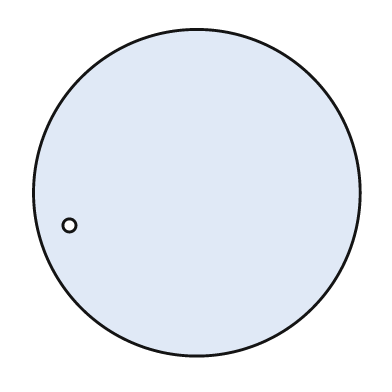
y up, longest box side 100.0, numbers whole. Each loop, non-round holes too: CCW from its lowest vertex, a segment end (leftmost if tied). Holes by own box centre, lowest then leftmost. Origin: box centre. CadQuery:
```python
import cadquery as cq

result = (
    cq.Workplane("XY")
    .moveTo(0.0, 0.0)
    .circle(50.0)
    .moveTo(-39.0, -10.0)
    .circle(2.0)
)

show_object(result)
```